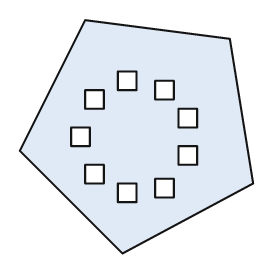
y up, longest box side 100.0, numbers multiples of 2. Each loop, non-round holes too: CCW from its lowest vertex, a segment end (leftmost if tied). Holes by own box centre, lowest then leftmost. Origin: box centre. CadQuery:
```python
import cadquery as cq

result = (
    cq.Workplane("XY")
    .moveTo(-6.0, -50.0)
    .lineTo(50.0, -20.0)
    .lineTo(40.0, 42.0)
    .lineTo(-22.0, 50.0)
    .lineTo(-50.0, -6.0)
    .close()
    .moveTo(-8.0, -28.0)
    .lineTo(0.0, -28.0)
    .lineTo(0.0, -20.0)
    .lineTo(-8.0, -20.0)
    .close()
    .moveTo(8.0, -26.0)
    .lineTo(16.0, -26.0)
    .lineTo(16.0, -18.0)
    .lineTo(8.0, -18.0)
    .close()
    .moveTo(-22.0, -20.0)
    .lineTo(-14.0, -20.0)
    .lineTo(-14.0, -12.0)
    .lineTo(-22.0, -12.0)
    .close()
    .moveTo(18.0, -12.0)
    .lineTo(26.0, -12.0)
    .lineTo(26.0, -4.0)
    .lineTo(18.0, -4.0)
    .close()
    .moveTo(-28.0, -4.0)
    .lineTo(-20.0, -4.0)
    .lineTo(-20.0, 4.0)
    .lineTo(-28.0, 4.0)
    .close()
    .moveTo(18.0, 4.0)
    .lineTo(26.0, 4.0)
    .lineTo(26.0, 12.0)
    .lineTo(18.0, 12.0)
    .close()
    .moveTo(-22.0, 12.0)
    .lineTo(-14.0, 12.0)
    .lineTo(-14.0, 20.0)
    .lineTo(-22.0, 20.0)
    .close()
    .moveTo(8.0, 16.0)
    .lineTo(16.0, 16.0)
    .lineTo(16.0, 24.0)
    .lineTo(8.0, 24.0)
    .close()
    .moveTo(-8.0, 20.0)
    .lineTo(0.0, 20.0)
    .lineTo(0.0, 28.0)
    .lineTo(-8.0, 28.0)
    .close()
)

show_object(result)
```